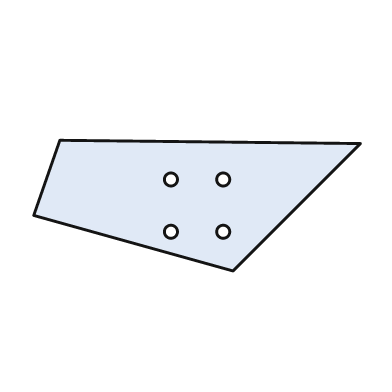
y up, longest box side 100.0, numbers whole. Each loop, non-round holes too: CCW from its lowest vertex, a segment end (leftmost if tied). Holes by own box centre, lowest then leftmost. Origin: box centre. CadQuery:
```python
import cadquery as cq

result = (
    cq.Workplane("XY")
    .moveTo(11.0, -20.0)
    .lineTo(50.0, 19.0)
    .lineTo(-42.0, 20.0)
    .lineTo(-50.0, -3.0)
    .close()
    .moveTo(-8.0, -8.0)
    .circle(2.0)
    .moveTo(8.0, -8.0)
    .circle(2.0)
    .moveTo(-8.0, 8.0)
    .circle(2.0)
    .moveTo(8.0, 8.0)
    .circle(2.0)
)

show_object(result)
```